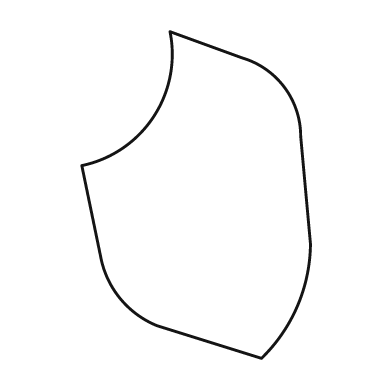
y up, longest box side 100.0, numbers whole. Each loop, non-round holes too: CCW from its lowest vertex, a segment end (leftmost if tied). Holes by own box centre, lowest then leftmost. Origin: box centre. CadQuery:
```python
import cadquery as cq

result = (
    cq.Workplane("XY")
    .moveTo(20.0, -50.0)
    .threePointArc((31.0, -34.0), (35.0, -15.0))
    .lineTo(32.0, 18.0)
    .threePointArc((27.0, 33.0), (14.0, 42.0))
    .lineTo(-8.0, 50.0)
    .threePointArc((-13.0, 24.0), (-35.0, 9.0))
    .lineTo(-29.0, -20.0)
    .threePointArc((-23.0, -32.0), (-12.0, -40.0))
    .close()
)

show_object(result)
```